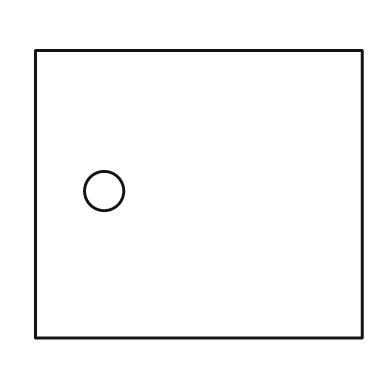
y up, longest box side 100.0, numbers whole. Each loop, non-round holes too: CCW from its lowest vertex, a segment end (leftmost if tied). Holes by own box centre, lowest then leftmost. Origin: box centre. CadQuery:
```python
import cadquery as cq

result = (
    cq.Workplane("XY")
    .moveTo(-50.0, -44.0)
    .lineTo(50.0, -44.0)
    .lineTo(50.0, 44.0)
    .lineTo(-50.0, 44.0)
    .close()
    .moveTo(-29.0, 1.0)
    .circle(6.0)
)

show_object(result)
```